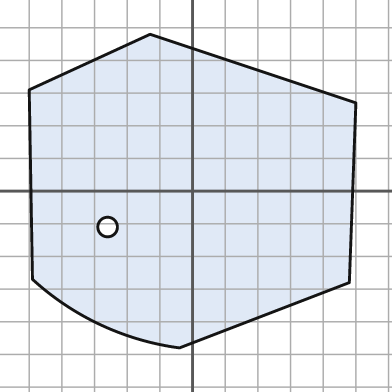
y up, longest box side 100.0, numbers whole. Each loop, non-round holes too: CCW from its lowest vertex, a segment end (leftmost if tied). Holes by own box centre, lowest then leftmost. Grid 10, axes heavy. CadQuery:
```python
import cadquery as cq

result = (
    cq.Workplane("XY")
    .moveTo(-4.0, -48.0)
    .lineTo(48.0, -28.0)
    .lineTo(50.0, 27.0)
    .lineTo(-13.0, 48.0)
    .lineTo(-50.0, 31.0)
    .lineTo(-49.0, -27.0)
    .threePointArc((-28.0, -41.0), (-4.0, -48.0))
    .close()
    .moveTo(-26.0, -11.0)
    .circle(3.0)
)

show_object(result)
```